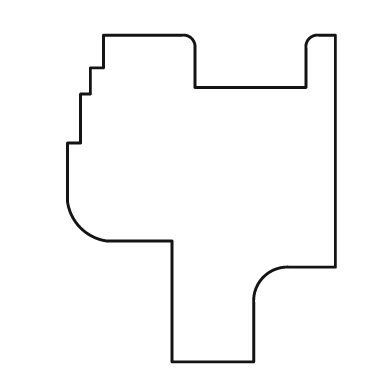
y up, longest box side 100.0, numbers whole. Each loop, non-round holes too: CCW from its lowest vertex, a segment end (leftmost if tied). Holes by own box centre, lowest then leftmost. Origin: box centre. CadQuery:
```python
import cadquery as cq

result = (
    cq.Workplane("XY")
    .moveTo(-9.0, -50.0)
    .lineTo(16.0, -50.0)
    .lineTo(16.0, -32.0)
    .threePointArc((19.0, -24.0), (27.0, -21.0))
    .lineTo(41.0, -21.0)
    .lineTo(41.0, 50.0)
    .lineTo(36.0, 50.0)
    .threePointArc((33.0, 49.0), (32.0, 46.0))
    .lineTo(32.0, 34.0)
    .lineTo(-2.0, 34.0)
    .lineTo(-2.0, 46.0)
    .threePointArc((-3.0, 49.0), (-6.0, 50.0))
    .lineTo(-30.0, 50.0)
    .lineTo(-30.0, 40.0)
    .lineTo(-34.0, 40.0)
    .lineTo(-34.0, 32.0)
    .lineTo(-37.0, 32.0)
    .lineTo(-37.0, 17.0)
    .lineTo(-41.0, 17.0)
    .lineTo(-41.0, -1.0)
    .threePointArc((-37.0, -9.0), (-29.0, -13.0))
    .lineTo(-9.0, -13.0)
    .close()
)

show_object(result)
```